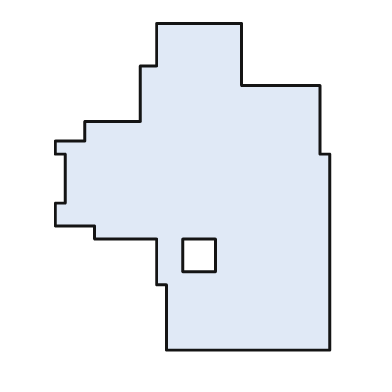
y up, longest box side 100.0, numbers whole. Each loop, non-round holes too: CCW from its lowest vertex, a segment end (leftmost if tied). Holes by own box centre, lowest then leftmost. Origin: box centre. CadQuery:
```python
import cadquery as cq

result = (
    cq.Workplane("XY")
    .moveTo(-8.0, -50.0)
    .lineTo(42.0, -50.0)
    .lineTo(42.0, 10.0)
    .lineTo(39.0, 10.0)
    .lineTo(39.0, 31.0)
    .lineTo(15.0, 31.0)
    .lineTo(15.0, 50.0)
    .lineTo(-11.0, 50.0)
    .lineTo(-11.0, 37.0)
    .lineTo(-16.0, 37.0)
    .lineTo(-16.0, 20.0)
    .lineTo(-33.0, 20.0)
    .lineTo(-33.0, 14.0)
    .lineTo(-42.0, 14.0)
    .lineTo(-42.0, 10.0)
    .lineTo(-39.0, 10.0)
    .lineTo(-39.0, -5.0)
    .lineTo(-42.0, -5.0)
    .lineTo(-42.0, -12.0)
    .lineTo(-30.0, -12.0)
    .lineTo(-30.0, -16.0)
    .lineTo(-11.0, -16.0)
    .lineTo(-11.0, -30.0)
    .lineTo(-8.0, -30.0)
    .close()
    .moveTo(-3.0, -26.0)
    .lineTo(7.0, -26.0)
    .lineTo(7.0, -16.0)
    .lineTo(-3.0, -16.0)
    .close()
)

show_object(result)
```